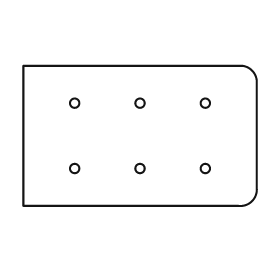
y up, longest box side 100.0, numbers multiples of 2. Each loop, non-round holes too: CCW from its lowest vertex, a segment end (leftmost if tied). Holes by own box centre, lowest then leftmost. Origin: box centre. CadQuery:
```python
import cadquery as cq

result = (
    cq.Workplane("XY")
    .moveTo(-50.0, -30.0)
    .lineTo(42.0, -30.0)
    .threePointArc((48.0, -28.0), (50.0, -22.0))
    .lineTo(50.0, 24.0)
    .threePointArc((48.0, 28.0), (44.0, 30.0))
    .lineTo(-50.0, 30.0)
    .close()
    .moveTo(-28.0, -14.0)
    .circle(2.0)
    .moveTo(0.0, -14.0)
    .circle(2.0)
    .moveTo(28.0, -14.0)
    .circle(2.0)
    .moveTo(-28.0, 14.0)
    .circle(2.0)
    .moveTo(0.0, 14.0)
    .circle(2.0)
    .moveTo(28.0, 14.0)
    .circle(2.0)
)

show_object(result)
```